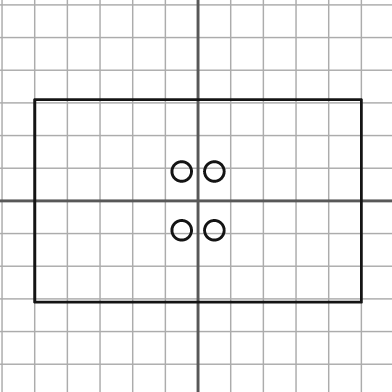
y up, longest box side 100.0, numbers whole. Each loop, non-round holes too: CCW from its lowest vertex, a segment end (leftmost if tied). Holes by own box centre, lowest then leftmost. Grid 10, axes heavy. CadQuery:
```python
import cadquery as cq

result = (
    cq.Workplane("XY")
    .moveTo(-50.0, -31.0)
    .lineTo(50.0, -31.0)
    .lineTo(50.0, 31.0)
    .lineTo(-50.0, 31.0)
    .close()
    .moveTo(-5.0, -9.0)
    .circle(3.0)
    .moveTo(5.0, -9.0)
    .circle(3.0)
    .moveTo(-5.0, 9.0)
    .circle(3.0)
    .moveTo(5.0, 9.0)
    .circle(3.0)
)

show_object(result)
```